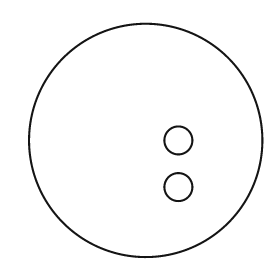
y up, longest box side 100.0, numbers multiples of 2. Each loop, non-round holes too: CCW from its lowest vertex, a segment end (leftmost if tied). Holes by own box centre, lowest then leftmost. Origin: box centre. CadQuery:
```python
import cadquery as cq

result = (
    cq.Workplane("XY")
    .moveTo(0.0, 0.0)
    .circle(50.0)
    .moveTo(14.0, -20.0)
    .circle(6.0)
    .moveTo(14.0, 0.0)
    .circle(6.0)
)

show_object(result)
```